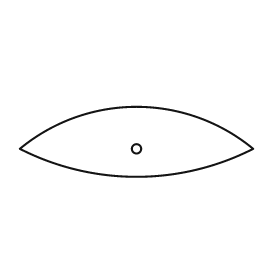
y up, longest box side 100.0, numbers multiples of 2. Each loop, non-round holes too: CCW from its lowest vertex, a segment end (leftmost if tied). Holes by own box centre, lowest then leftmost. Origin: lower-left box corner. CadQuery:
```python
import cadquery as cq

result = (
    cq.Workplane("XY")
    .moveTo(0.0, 12.0)
    .threePointArc((50.0, 0.0), (100.0, 12.0))
    .threePointArc((50.0, 30.0), (0.0, 12.0))
    .close()
    .moveTo(50.0, 12.0)
    .circle(2.0)
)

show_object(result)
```